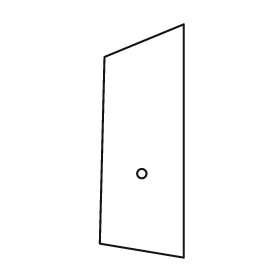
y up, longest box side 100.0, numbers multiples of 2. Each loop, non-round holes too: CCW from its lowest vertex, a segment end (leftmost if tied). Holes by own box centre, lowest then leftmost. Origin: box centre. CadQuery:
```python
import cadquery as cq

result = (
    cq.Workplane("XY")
    .moveTo(18.0, -50.0)
    .lineTo(18.0, 50.0)
    .lineTo(-16.0, 36.0)
    .lineTo(-18.0, -44.0)
    .close()
    .moveTo(0.0, -14.0)
    .circle(2.0)
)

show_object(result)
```